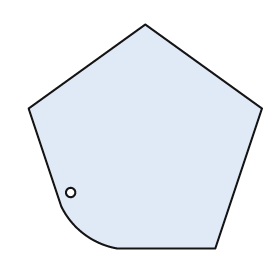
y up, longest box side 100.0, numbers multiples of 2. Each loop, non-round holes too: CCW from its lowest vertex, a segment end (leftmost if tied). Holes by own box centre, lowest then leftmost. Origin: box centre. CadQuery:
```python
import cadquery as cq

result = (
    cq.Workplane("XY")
    .moveTo(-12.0, -48.0)
    .lineTo(30.0, -48.0)
    .lineTo(50.0, 12.0)
    .lineTo(0.0, 48.0)
    .lineTo(-50.0, 12.0)
    .lineTo(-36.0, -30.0)
    .threePointArc((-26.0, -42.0), (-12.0, -48.0))
    .close()
    .moveTo(-32.0, -24.0)
    .circle(2.0)
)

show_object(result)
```